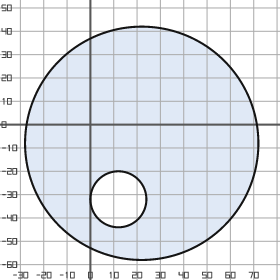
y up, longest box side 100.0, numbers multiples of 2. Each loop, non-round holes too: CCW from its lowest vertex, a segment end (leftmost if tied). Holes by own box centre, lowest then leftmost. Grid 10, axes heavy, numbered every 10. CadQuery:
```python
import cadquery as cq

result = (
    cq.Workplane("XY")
    .moveTo(22.0, -8.0)
    .circle(50.0)
    .moveTo(12.0, -32.0)
    .circle(12.0)
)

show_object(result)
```